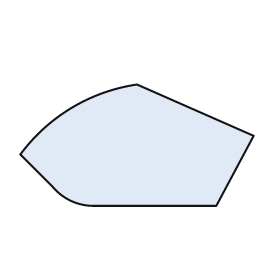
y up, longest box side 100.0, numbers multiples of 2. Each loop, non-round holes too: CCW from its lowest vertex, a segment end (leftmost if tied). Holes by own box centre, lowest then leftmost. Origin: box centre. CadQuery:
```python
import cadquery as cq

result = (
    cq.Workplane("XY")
    .moveTo(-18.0, -26.0)
    .lineTo(34.0, -26.0)
    .lineTo(50.0, 4.0)
    .lineTo(0.0, 26.0)
    .threePointArc((-28.0, 16.0), (-50.0, -4.0))
    .lineTo(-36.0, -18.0)
    .threePointArc((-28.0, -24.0), (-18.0, -26.0))
    .close()
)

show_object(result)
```